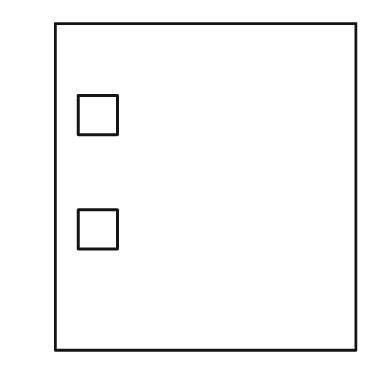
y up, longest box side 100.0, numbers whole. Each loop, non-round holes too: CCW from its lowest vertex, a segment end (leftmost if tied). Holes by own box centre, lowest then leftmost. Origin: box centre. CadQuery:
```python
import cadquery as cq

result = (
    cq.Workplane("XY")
    .moveTo(-46.0, -50.0)
    .lineTo(46.0, -50.0)
    .lineTo(46.0, 50.0)
    .lineTo(-46.0, 50.0)
    .close()
    .moveTo(-39.0, -19.0)
    .lineTo(-27.0, -19.0)
    .lineTo(-27.0, -7.0)
    .lineTo(-39.0, -7.0)
    .close()
    .moveTo(-39.0, 16.0)
    .lineTo(-27.0, 16.0)
    .lineTo(-27.0, 28.0)
    .lineTo(-39.0, 28.0)
    .close()
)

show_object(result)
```